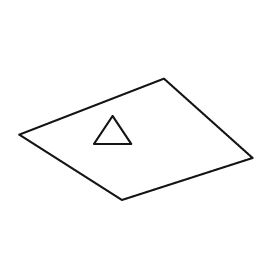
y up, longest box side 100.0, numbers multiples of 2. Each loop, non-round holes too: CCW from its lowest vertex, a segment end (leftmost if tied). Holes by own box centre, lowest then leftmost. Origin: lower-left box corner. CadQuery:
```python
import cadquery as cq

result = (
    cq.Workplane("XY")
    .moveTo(44.0, 0.0)
    .lineTo(100.0, 18.0)
    .lineTo(62.0, 52.0)
    .lineTo(0.0, 28.0)
    .close()
    .moveTo(32.0, 24.0)
    .lineTo(48.0, 24.0)
    .lineTo(40.0, 36.0)
    .close()
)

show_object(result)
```